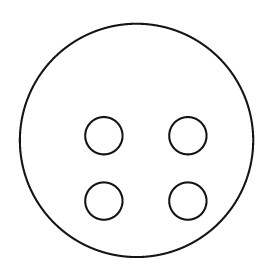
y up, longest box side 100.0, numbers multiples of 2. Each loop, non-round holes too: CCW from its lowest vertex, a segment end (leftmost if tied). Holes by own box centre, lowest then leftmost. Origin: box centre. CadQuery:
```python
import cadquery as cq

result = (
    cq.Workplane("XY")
    .moveTo(0.0, 0.0)
    .circle(50.0)
    .moveTo(-14.0, -26.0)
    .circle(8.0)
    .moveTo(22.0, -26.0)
    .circle(8.0)
    .moveTo(-14.0, 2.0)
    .circle(8.0)
    .moveTo(22.0, 2.0)
    .circle(8.0)
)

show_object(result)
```